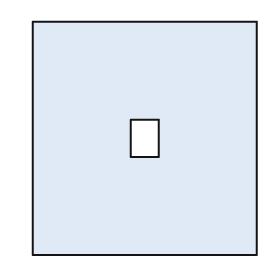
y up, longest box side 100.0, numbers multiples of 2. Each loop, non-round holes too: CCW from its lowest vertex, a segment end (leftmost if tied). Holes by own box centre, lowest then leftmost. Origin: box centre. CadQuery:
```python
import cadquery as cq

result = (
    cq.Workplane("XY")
    .moveTo(-48.0, -50.0)
    .lineTo(48.0, -50.0)
    .lineTo(48.0, 50.0)
    .lineTo(-48.0, 50.0)
    .close()
    .moveTo(-6.0, -8.0)
    .lineTo(6.0, -8.0)
    .lineTo(6.0, 8.0)
    .lineTo(-6.0, 8.0)
    .close()
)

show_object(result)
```